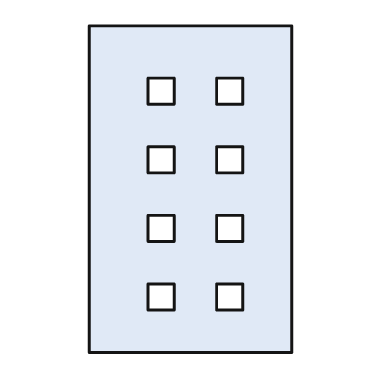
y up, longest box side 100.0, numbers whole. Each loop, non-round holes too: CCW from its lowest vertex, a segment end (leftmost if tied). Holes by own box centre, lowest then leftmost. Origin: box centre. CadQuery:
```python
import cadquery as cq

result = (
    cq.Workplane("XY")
    .moveTo(-31.0, -50.0)
    .lineTo(31.0, -50.0)
    .lineTo(31.0, 50.0)
    .lineTo(-31.0, 50.0)
    .close()
    .moveTo(-13.0, -37.0)
    .lineTo(-5.0, -37.0)
    .lineTo(-5.0, -29.0)
    .lineTo(-13.0, -29.0)
    .close()
    .moveTo(8.0, -37.0)
    .lineTo(16.0, -37.0)
    .lineTo(16.0, -29.0)
    .lineTo(8.0, -29.0)
    .close()
    .moveTo(-13.0, -16.0)
    .lineTo(-5.0, -16.0)
    .lineTo(-5.0, -8.0)
    .lineTo(-13.0, -8.0)
    .close()
    .moveTo(8.0, -16.0)
    .lineTo(16.0, -16.0)
    .lineTo(16.0, -8.0)
    .lineTo(8.0, -8.0)
    .close()
    .moveTo(-13.0, 5.0)
    .lineTo(-5.0, 5.0)
    .lineTo(-5.0, 13.0)
    .lineTo(-13.0, 13.0)
    .close()
    .moveTo(8.0, 5.0)
    .lineTo(16.0, 5.0)
    .lineTo(16.0, 13.0)
    .lineTo(8.0, 13.0)
    .close()
    .moveTo(-13.0, 26.0)
    .lineTo(-5.0, 26.0)
    .lineTo(-5.0, 34.0)
    .lineTo(-13.0, 34.0)
    .close()
    .moveTo(8.0, 26.0)
    .lineTo(16.0, 26.0)
    .lineTo(16.0, 34.0)
    .lineTo(8.0, 34.0)
    .close()
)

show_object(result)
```